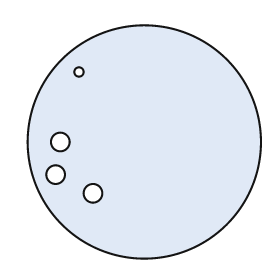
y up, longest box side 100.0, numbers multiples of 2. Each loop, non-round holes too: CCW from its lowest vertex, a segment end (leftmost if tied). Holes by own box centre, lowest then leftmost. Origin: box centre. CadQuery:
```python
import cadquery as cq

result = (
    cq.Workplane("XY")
    .moveTo(0.0, 0.0)
    .circle(50.0)
    .moveTo(-22.0, -22.0)
    .circle(4.0)
    .moveTo(-38.0, -14.0)
    .circle(4.0)
    .moveTo(-36.0, 0.0)
    .circle(4.0)
    .moveTo(-28.0, 30.0)
    .circle(2.0)
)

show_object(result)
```